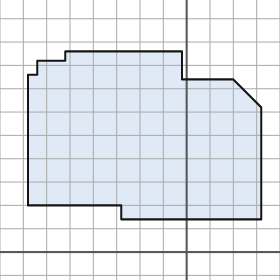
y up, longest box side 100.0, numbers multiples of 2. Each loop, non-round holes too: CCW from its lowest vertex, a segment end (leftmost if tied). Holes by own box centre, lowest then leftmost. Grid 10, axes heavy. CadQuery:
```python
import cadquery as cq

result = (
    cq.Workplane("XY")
    .moveTo(-28.0, 14.0)
    .lineTo(32.0, 14.0)
    .lineTo(32.0, 62.0)
    .lineTo(20.0, 74.0)
    .lineTo(-2.0, 74.0)
    .lineTo(-2.0, 86.0)
    .lineTo(-52.0, 86.0)
    .lineTo(-52.0, 82.0)
    .lineTo(-64.0, 82.0)
    .lineTo(-64.0, 76.0)
    .lineTo(-68.0, 76.0)
    .lineTo(-68.0, 20.0)
    .lineTo(-28.0, 20.0)
    .close()
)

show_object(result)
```